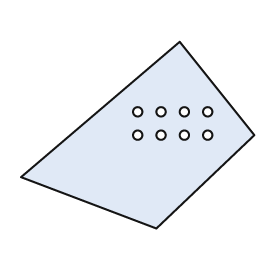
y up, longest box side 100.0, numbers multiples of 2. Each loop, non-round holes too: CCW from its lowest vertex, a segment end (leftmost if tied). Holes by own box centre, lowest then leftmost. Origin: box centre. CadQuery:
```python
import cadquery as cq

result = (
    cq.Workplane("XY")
    .moveTo(8.0, -40.0)
    .lineTo(50.0, 0.0)
    .lineTo(18.0, 40.0)
    .lineTo(-50.0, -18.0)
    .close()
    .moveTo(0.0, 0.0)
    .circle(2.0)
    .moveTo(10.0, 0.0)
    .circle(2.0)
    .moveTo(20.0, 0.0)
    .circle(2.0)
    .moveTo(30.0, 0.0)
    .circle(2.0)
    .moveTo(0.0, 10.0)
    .circle(2.0)
    .moveTo(10.0, 10.0)
    .circle(2.0)
    .moveTo(20.0, 10.0)
    .circle(2.0)
    .moveTo(30.0, 10.0)
    .circle(2.0)
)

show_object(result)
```